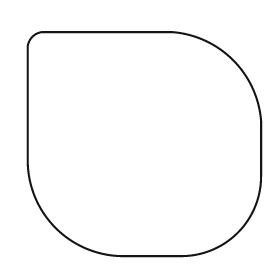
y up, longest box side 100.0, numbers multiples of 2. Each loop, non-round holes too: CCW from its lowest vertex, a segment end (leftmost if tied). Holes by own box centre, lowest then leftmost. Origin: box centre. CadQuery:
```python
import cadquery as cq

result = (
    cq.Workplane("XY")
    .moveTo(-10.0, -48.0)
    .lineTo(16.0, -48.0)
    .threePointArc((40.0, -38.0), (50.0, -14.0))
    .lineTo(50.0, 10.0)
    .threePointArc((38.0, 36.0), (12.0, 48.0))
    .lineTo(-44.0, 48.0)
    .threePointArc((-48.0, 46.0), (-50.0, 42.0))
    .lineTo(-50.0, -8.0)
    .threePointArc((-38.0, -36.0), (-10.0, -48.0))
    .close()
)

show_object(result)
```